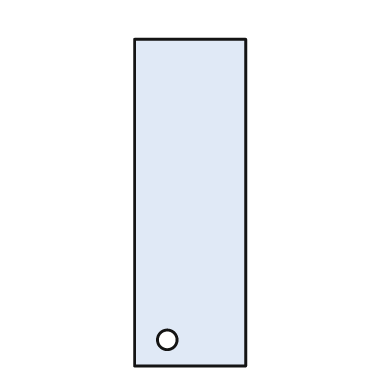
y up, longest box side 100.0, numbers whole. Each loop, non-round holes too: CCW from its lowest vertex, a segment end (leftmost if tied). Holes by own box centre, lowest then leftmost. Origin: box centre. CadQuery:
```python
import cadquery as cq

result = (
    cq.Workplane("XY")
    .moveTo(-17.0, -50.0)
    .lineTo(17.0, -50.0)
    .lineTo(17.0, 50.0)
    .lineTo(-17.0, 50.0)
    .close()
    .moveTo(-7.0, -42.0)
    .circle(3.0)
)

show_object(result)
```